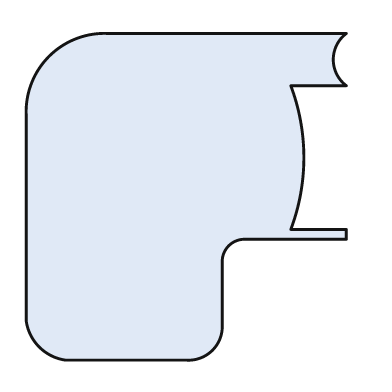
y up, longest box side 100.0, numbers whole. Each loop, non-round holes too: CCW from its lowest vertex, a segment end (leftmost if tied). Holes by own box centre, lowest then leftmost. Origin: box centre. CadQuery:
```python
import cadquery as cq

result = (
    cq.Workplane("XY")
    .moveTo(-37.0, -50.0)
    .lineTo(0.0, -50.0)
    .threePointArc((8.0, -47.0), (11.0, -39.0))
    .lineTo(11.0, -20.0)
    .threePointArc((13.0, -15.0), (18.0, -13.0))
    .lineTo(49.0, -13.0)
    .lineTo(49.0, -10.0)
    .lineTo(32.0, -10.0)
    .threePointArc((36.0, 12.0), (32.0, 34.0))
    .lineTo(49.0, 34.0)
    .threePointArc((45.0, 42.0), (49.0, 50.0))
    .lineTo(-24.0, 50.0)
    .threePointArc((-42.0, 43.0), (-49.0, 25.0))
    .lineTo(-49.0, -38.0)
    .threePointArc((-45.0, -46.0), (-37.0, -50.0))
    .close()
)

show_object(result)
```